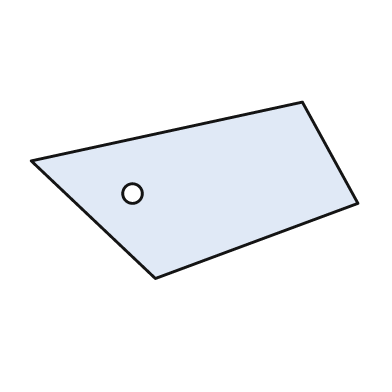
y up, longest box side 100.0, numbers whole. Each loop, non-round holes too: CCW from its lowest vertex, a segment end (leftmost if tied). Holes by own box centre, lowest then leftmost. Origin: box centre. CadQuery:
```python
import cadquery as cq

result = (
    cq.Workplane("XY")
    .moveTo(-12.0, -27.0)
    .lineTo(50.0, -4.0)
    .lineTo(33.0, 27.0)
    .lineTo(-50.0, 9.0)
    .close()
    .moveTo(-19.0, -1.0)
    .circle(3.0)
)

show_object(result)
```